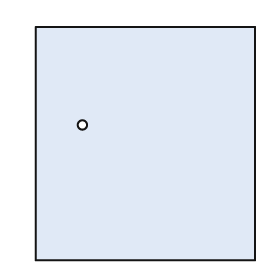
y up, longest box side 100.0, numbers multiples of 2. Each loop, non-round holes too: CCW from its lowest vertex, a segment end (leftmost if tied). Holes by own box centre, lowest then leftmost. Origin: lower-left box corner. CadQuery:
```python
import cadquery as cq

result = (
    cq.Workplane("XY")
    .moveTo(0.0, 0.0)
    .lineTo(94.0, 0.0)
    .lineTo(94.0, 100.0)
    .lineTo(0.0, 100.0)
    .close()
    .moveTo(20.0, 58.0)
    .circle(2.0)
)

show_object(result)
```